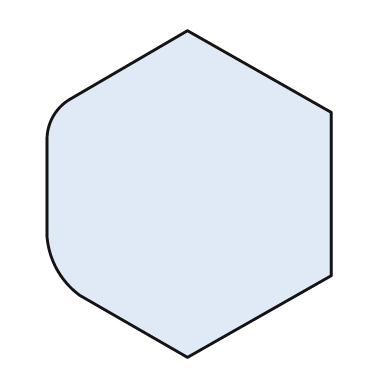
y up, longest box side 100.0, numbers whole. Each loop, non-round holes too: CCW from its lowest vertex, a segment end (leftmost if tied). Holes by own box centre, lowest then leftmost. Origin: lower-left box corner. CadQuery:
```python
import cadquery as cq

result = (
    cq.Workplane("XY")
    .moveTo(43.0, 0.0)
    .lineTo(87.0, 25.0)
    .lineTo(87.0, 75.0)
    .lineTo(43.0, 100.0)
    .lineTo(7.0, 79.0)
    .threePointArc((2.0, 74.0), (0.0, 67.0))
    .lineTo(0.0, 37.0)
    .threePointArc((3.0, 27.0), (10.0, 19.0))
    .close()
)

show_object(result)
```